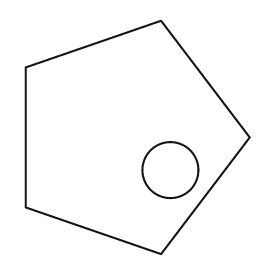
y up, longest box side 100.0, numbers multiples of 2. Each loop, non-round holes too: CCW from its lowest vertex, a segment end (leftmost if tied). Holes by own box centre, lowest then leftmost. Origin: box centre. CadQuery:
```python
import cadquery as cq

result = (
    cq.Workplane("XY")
    .moveTo(10.0, -50.0)
    .lineTo(48.0, 0.0)
    .lineTo(10.0, 50.0)
    .lineTo(-48.0, 30.0)
    .lineTo(-48.0, -30.0)
    .close()
    .moveTo(14.0, -14.0)
    .circle(12.0)
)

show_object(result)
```